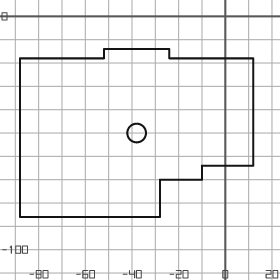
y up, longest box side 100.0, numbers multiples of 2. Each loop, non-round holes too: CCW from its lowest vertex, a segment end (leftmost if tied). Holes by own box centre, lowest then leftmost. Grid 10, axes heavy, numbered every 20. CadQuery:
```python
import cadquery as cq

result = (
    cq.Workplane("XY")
    .moveTo(-88.0, -86.0)
    .lineTo(-28.0, -86.0)
    .lineTo(-28.0, -70.0)
    .lineTo(-10.0, -70.0)
    .lineTo(-10.0, -64.0)
    .lineTo(12.0, -64.0)
    .lineTo(12.0, -18.0)
    .lineTo(-24.0, -18.0)
    .lineTo(-24.0, -14.0)
    .lineTo(-52.0, -14.0)
    .lineTo(-52.0, -18.0)
    .lineTo(-88.0, -18.0)
    .close()
    .moveTo(-38.0, -50.0)
    .circle(4.0)
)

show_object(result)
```